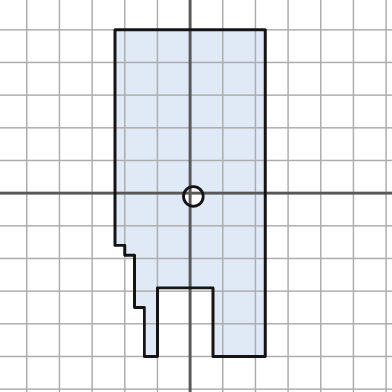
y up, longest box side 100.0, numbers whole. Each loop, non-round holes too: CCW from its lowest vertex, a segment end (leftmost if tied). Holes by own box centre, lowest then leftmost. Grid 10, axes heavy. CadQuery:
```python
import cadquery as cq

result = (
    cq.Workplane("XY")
    .moveTo(-14.0, -50.0)
    .lineTo(-10.0, -50.0)
    .lineTo(-10.0, -29.0)
    .lineTo(7.0, -29.0)
    .lineTo(7.0, -50.0)
    .lineTo(23.0, -50.0)
    .lineTo(23.0, 50.0)
    .lineTo(-23.0, 50.0)
    .lineTo(-23.0, -16.0)
    .lineTo(-20.0, -16.0)
    .lineTo(-20.0, -19.0)
    .lineTo(-17.0, -19.0)
    .lineTo(-17.0, -35.0)
    .lineTo(-14.0, -35.0)
    .close()
    .moveTo(1.0, -1.0)
    .circle(3.0)
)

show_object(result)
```